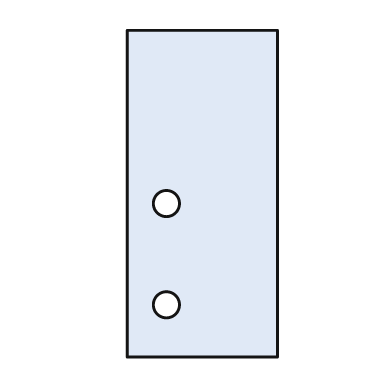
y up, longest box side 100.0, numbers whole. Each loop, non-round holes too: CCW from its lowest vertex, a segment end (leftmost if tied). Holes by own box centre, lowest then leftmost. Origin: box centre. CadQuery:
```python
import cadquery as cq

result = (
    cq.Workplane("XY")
    .moveTo(-23.0, -50.0)
    .lineTo(23.0, -50.0)
    .lineTo(23.0, 50.0)
    .lineTo(-23.0, 50.0)
    .close()
    .moveTo(-11.0, -34.0)
    .circle(4.0)
    .moveTo(-11.0, -3.0)
    .circle(4.0)
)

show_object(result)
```